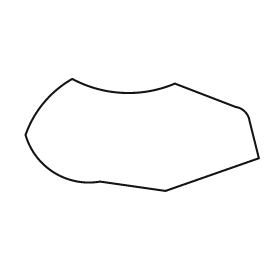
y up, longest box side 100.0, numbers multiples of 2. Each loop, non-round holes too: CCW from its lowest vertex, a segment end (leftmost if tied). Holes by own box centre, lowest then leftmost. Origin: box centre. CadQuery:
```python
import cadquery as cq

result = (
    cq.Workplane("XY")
    .moveTo(10.0, -24.0)
    .lineTo(50.0, -10.0)
    .lineTo(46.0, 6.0)
    .threePointArc((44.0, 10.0), (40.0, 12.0))
    .lineTo(14.0, 22.0)
    .threePointArc((-8.0, 18.0), (-30.0, 24.0))
    .threePointArc((-42.0, 14.0), (-50.0, 0.0))
    .threePointArc((-38.0, -16.0), (-18.0, -20.0))
    .close()
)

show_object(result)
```